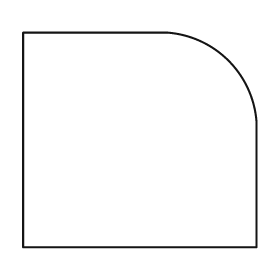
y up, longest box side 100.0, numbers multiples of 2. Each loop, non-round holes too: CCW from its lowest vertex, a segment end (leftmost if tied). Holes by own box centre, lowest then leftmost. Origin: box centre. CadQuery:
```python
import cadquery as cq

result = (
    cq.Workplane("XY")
    .moveTo(-50.0, -46.0)
    .lineTo(50.0, -46.0)
    .lineTo(50.0, 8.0)
    .threePointArc((38.0, 34.0), (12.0, 46.0))
    .lineTo(-50.0, 46.0)
    .close()
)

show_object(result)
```